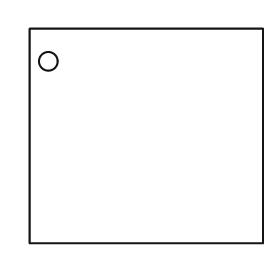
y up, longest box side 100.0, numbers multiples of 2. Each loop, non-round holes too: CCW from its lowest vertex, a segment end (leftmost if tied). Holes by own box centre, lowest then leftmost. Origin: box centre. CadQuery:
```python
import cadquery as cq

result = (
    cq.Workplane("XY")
    .moveTo(-50.0, -46.0)
    .lineTo(50.0, -46.0)
    .lineTo(50.0, 46.0)
    .lineTo(-50.0, 46.0)
    .close()
    .moveTo(-42.0, 32.0)
    .circle(4.0)
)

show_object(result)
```